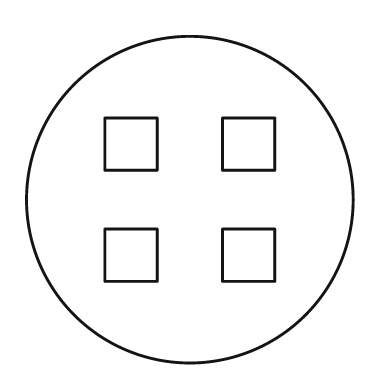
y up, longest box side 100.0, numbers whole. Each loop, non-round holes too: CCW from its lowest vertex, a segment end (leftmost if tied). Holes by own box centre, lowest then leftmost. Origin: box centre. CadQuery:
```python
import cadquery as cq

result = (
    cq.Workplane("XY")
    .moveTo(0.0, 0.0)
    .circle(50.0)
    .moveTo(-26.0, -25.0)
    .lineTo(-10.0, -25.0)
    .lineTo(-10.0, -9.0)
    .lineTo(-26.0, -9.0)
    .close()
    .moveTo(10.0, -25.0)
    .lineTo(26.0, -25.0)
    .lineTo(26.0, -9.0)
    .lineTo(10.0, -9.0)
    .close()
    .moveTo(-26.0, 9.0)
    .lineTo(-10.0, 9.0)
    .lineTo(-10.0, 25.0)
    .lineTo(-26.0, 25.0)
    .close()
    .moveTo(10.0, 9.0)
    .lineTo(26.0, 9.0)
    .lineTo(26.0, 25.0)
    .lineTo(10.0, 25.0)
    .close()
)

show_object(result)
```